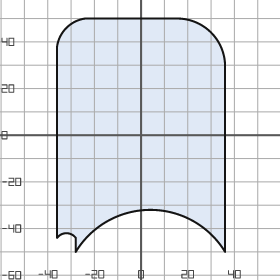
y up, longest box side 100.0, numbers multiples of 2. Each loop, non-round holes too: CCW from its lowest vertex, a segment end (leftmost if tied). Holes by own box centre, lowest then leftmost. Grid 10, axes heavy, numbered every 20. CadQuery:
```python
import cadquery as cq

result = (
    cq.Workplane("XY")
    .moveTo(-28.0, -50.0)
    .threePointArc((4.0, -32.0), (36.0, -50.0))
    .lineTo(36.0, 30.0)
    .threePointArc((30.0, 44.0), (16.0, 50.0))
    .lineTo(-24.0, 50.0)
    .threePointArc((-32.0, 46.0), (-36.0, 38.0))
    .lineTo(-36.0, -44.0)
    .threePointArc((-32.0, -42.0), (-28.0, -44.0))
    .close()
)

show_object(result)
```